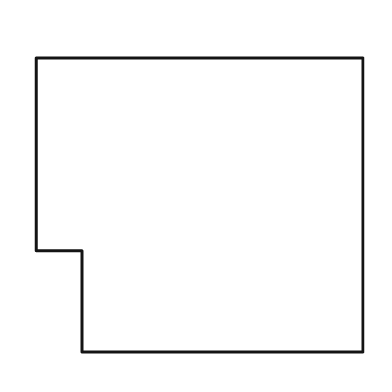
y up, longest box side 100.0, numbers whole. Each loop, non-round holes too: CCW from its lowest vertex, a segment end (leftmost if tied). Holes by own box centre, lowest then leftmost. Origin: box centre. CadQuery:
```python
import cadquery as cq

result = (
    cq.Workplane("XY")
    .moveTo(-36.0, -45.0)
    .lineTo(50.0, -45.0)
    .lineTo(50.0, 45.0)
    .lineTo(-50.0, 45.0)
    .lineTo(-50.0, -14.0)
    .lineTo(-36.0, -14.0)
    .close()
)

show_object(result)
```